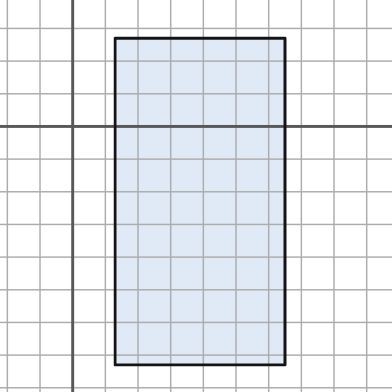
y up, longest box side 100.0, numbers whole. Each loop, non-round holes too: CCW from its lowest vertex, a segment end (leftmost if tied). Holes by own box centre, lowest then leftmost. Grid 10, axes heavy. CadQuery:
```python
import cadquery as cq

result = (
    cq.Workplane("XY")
    .moveTo(13.0, -73.0)
    .lineTo(65.0, -73.0)
    .lineTo(65.0, 27.0)
    .lineTo(13.0, 27.0)
    .close()
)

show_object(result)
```